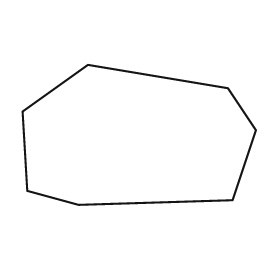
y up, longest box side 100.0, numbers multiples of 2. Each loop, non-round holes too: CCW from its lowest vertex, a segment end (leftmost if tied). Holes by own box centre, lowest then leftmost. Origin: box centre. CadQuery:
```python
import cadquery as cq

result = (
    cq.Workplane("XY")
    .moveTo(-26.0, -30.0)
    .lineTo(40.0, -28.0)
    .lineTo(50.0, 2.0)
    .lineTo(38.0, 20.0)
    .lineTo(-22.0, 30.0)
    .lineTo(-50.0, 10.0)
    .lineTo(-48.0, -24.0)
    .close()
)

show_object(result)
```